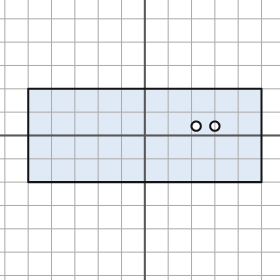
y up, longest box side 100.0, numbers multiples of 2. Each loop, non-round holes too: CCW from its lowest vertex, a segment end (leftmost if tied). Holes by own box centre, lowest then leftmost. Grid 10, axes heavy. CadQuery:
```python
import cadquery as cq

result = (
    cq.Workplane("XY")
    .moveTo(-50.0, -20.0)
    .lineTo(50.0, -20.0)
    .lineTo(50.0, 20.0)
    .lineTo(-50.0, 20.0)
    .close()
    .moveTo(22.0, 4.0)
    .circle(2.0)
    .moveTo(30.0, 4.0)
    .circle(2.0)
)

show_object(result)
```